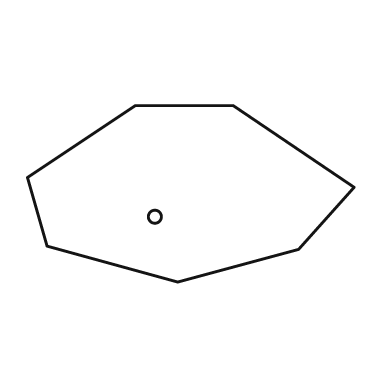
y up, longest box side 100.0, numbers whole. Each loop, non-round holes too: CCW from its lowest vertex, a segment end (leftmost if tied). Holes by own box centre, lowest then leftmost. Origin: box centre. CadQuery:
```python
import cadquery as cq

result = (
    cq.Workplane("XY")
    .moveTo(-4.0, -27.0)
    .lineTo(33.0, -17.0)
    .lineTo(50.0, 2.0)
    .lineTo(13.0, 27.0)
    .lineTo(-17.0, 27.0)
    .lineTo(-50.0, 5.0)
    .lineTo(-44.0, -16.0)
    .close()
    .moveTo(-11.0, -7.0)
    .circle(2.0)
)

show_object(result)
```